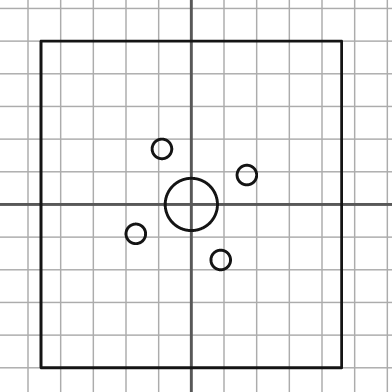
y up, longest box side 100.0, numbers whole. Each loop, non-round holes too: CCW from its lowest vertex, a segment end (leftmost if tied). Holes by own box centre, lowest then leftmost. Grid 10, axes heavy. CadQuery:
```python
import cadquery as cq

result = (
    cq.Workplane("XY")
    .moveTo(-46.0, -50.0)
    .lineTo(46.0, -50.0)
    .lineTo(46.0, 50.0)
    .lineTo(-46.0, 50.0)
    .close()
    .moveTo(9.0, -17.0)
    .circle(3.0)
    .moveTo(-17.0, -9.0)
    .circle(3.0)
    .moveTo(0.0, 0.0)
    .circle(8.0)
    .moveTo(17.0, 9.0)
    .circle(3.0)
    .moveTo(-9.0, 17.0)
    .circle(3.0)
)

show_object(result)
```